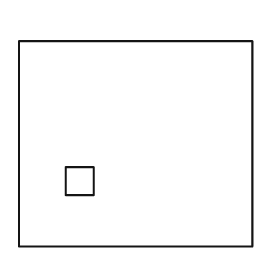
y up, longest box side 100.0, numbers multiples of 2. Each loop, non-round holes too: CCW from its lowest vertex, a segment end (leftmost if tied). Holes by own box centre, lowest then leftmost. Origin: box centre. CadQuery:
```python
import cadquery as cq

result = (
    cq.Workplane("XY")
    .moveTo(-50.0, -44.0)
    .lineTo(50.0, -44.0)
    .lineTo(50.0, 44.0)
    .lineTo(-50.0, 44.0)
    .close()
    .moveTo(-30.0, -22.0)
    .lineTo(-18.0, -22.0)
    .lineTo(-18.0, -10.0)
    .lineTo(-30.0, -10.0)
    .close()
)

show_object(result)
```